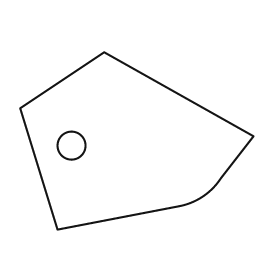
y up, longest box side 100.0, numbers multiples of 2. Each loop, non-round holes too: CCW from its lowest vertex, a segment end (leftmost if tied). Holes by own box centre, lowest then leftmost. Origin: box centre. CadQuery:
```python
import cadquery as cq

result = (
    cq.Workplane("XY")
    .moveTo(-34.0, -38.0)
    .lineTo(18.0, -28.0)
    .threePointArc((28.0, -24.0), (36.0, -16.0))
    .lineTo(50.0, 2.0)
    .lineTo(-14.0, 38.0)
    .lineTo(-50.0, 14.0)
    .close()
    .moveTo(-28.0, -2.0)
    .circle(6.0)
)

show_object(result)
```